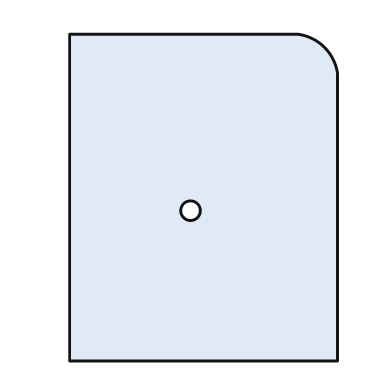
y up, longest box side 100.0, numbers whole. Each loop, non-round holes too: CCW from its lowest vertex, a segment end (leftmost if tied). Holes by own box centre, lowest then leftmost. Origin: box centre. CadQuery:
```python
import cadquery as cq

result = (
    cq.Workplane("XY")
    .moveTo(-41.0, -50.0)
    .lineTo(41.0, -50.0)
    .lineTo(41.0, 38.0)
    .threePointArc((37.0, 46.0), (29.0, 50.0))
    .lineTo(-41.0, 50.0)
    .close()
    .moveTo(-4.0, -4.0)
    .circle(3.0)
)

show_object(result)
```